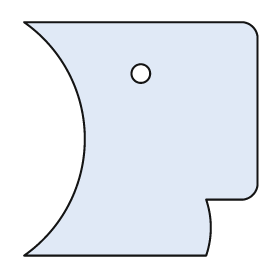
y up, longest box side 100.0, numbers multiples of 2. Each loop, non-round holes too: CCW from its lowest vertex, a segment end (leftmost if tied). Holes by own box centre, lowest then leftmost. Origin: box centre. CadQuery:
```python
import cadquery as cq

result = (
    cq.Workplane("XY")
    .moveTo(-50.0, -50.0)
    .lineTo(28.0, -50.0)
    .threePointArc((30.0, -38.0), (28.0, -26.0))
    .lineTo(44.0, -26.0)
    .threePointArc((48.0, -24.0), (50.0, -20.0))
    .lineTo(50.0, 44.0)
    .threePointArc((48.0, 48.0), (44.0, 50.0))
    .lineTo(-50.0, 50.0)
    .threePointArc((-24.0, 0.0), (-50.0, -50.0))
    .close()
    .moveTo(0.0, 28.0)
    .circle(4.0)
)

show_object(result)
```